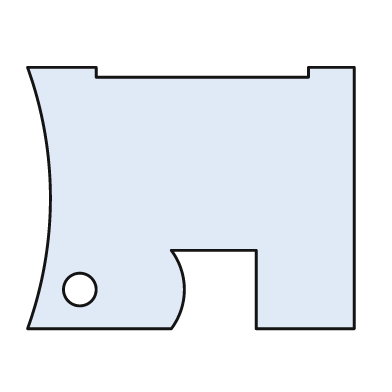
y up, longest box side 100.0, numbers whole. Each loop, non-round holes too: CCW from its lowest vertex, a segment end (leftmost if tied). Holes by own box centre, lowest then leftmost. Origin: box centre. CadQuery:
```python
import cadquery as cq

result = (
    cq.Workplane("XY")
    .moveTo(-50.0, -40.0)
    .lineTo(-6.0, -40.0)
    .threePointArc((-2.0, -28.0), (-6.0, -16.0))
    .lineTo(20.0, -16.0)
    .lineTo(20.0, -40.0)
    .lineTo(50.0, -40.0)
    .lineTo(50.0, 40.0)
    .lineTo(36.0, 40.0)
    .lineTo(36.0, 37.0)
    .lineTo(-29.0, 37.0)
    .lineTo(-29.0, 40.0)
    .lineTo(-50.0, 40.0)
    .threePointArc((-43.0, 0.0), (-50.0, -40.0))
    .close()
    .moveTo(-34.0, -28.0)
    .circle(5.0)
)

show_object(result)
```